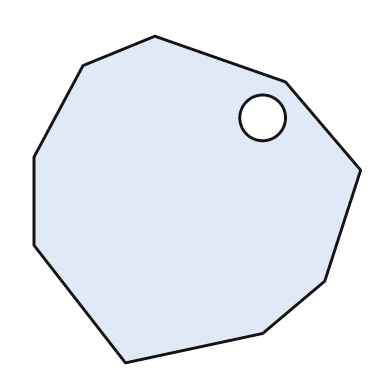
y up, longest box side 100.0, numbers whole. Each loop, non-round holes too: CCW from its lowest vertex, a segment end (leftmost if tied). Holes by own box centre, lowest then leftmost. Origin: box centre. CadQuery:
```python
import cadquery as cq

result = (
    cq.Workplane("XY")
    .moveTo(-22.0, -50.0)
    .lineTo(20.0, -41.0)
    .lineTo(39.0, -25.0)
    .lineTo(50.0, 9.0)
    .lineTo(27.0, 36.0)
    .lineTo(-13.0, 50.0)
    .lineTo(-35.0, 41.0)
    .lineTo(-50.0, 13.0)
    .lineTo(-50.0, -14.0)
    .close()
    .moveTo(20.0, 25.0)
    .circle(7.0)
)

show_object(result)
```